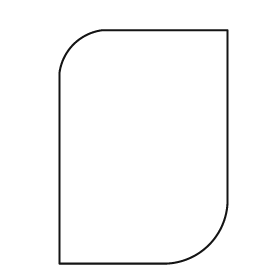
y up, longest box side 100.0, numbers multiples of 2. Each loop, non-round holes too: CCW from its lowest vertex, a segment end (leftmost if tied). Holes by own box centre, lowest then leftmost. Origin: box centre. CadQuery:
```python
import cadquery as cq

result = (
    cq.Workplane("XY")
    .moveTo(-36.0, -50.0)
    .lineTo(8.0, -50.0)
    .threePointArc((28.0, -42.0), (36.0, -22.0))
    .lineTo(36.0, 50.0)
    .lineTo(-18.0, 50.0)
    .threePointArc((-30.0, 44.0), (-36.0, 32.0))
    .close()
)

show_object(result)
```